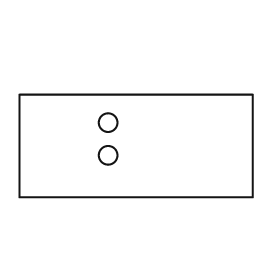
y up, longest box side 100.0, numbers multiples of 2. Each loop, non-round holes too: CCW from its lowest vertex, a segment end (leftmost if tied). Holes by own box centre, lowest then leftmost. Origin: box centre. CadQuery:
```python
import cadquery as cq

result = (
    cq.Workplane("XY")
    .moveTo(-50.0, -22.0)
    .lineTo(50.0, -22.0)
    .lineTo(50.0, 22.0)
    .lineTo(-50.0, 22.0)
    .close()
    .moveTo(-12.0, -4.0)
    .circle(4.0)
    .moveTo(-12.0, 10.0)
    .circle(4.0)
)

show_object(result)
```